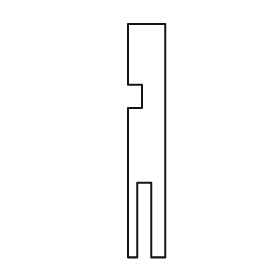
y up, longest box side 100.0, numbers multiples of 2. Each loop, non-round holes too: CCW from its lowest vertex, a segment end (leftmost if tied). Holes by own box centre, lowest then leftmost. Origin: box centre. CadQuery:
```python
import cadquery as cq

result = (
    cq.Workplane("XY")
    .moveTo(-8.0, -50.0)
    .lineTo(-4.0, -50.0)
    .lineTo(-4.0, -18.0)
    .lineTo(2.0, -18.0)
    .lineTo(2.0, -50.0)
    .lineTo(8.0, -50.0)
    .lineTo(8.0, 50.0)
    .lineTo(-8.0, 50.0)
    .lineTo(-8.0, 24.0)
    .lineTo(-2.0, 24.0)
    .lineTo(-2.0, 14.0)
    .lineTo(-8.0, 14.0)
    .close()
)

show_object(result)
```